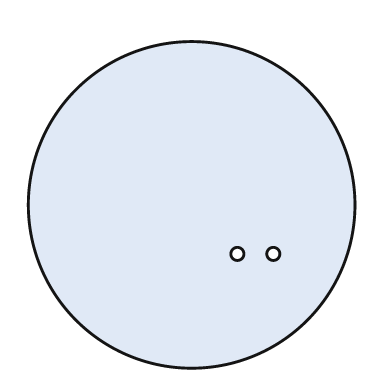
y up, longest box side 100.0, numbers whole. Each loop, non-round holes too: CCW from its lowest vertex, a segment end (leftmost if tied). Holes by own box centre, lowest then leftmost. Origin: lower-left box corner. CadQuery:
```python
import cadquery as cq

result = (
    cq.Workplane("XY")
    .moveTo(50.0, 50.0)
    .circle(50.0)
    .moveTo(64.0, 35.0)
    .circle(2.0)
    .moveTo(75.0, 35.0)
    .circle(2.0)
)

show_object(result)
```